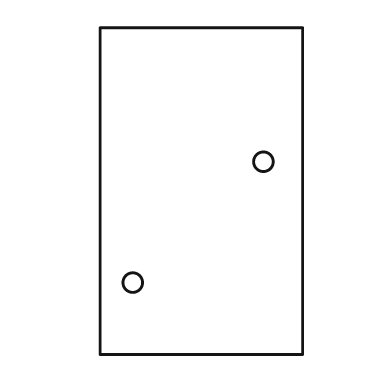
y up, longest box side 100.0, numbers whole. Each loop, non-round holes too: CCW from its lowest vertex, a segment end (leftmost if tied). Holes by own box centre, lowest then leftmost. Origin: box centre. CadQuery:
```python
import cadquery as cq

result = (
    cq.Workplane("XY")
    .moveTo(-31.0, -50.0)
    .lineTo(31.0, -50.0)
    .lineTo(31.0, 50.0)
    .lineTo(-31.0, 50.0)
    .close()
    .moveTo(-21.0, -28.0)
    .circle(3.0)
    .moveTo(19.0, 9.0)
    .circle(3.0)
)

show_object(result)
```